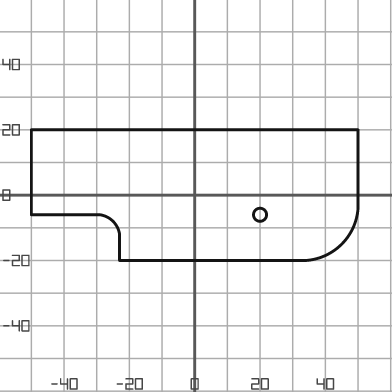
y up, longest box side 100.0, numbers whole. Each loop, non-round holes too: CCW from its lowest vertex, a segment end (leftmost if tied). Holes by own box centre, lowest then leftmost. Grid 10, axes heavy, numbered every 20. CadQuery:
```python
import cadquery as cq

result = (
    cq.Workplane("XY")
    .moveTo(-23.0, -20.0)
    .lineTo(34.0, -20.0)
    .threePointArc((45.0, -15.0), (50.0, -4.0))
    .lineTo(50.0, 20.0)
    .lineTo(-50.0, 20.0)
    .lineTo(-50.0, -6.0)
    .lineTo(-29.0, -6.0)
    .threePointArc((-25.0, -8.0), (-23.0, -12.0))
    .close()
    .moveTo(20.0, -6.0)
    .circle(2.0)
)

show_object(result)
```